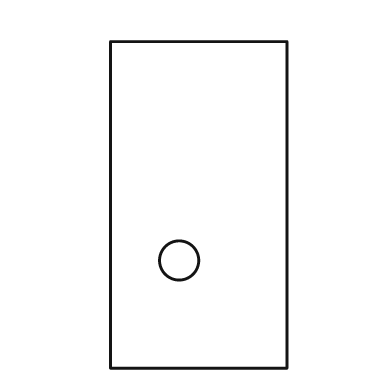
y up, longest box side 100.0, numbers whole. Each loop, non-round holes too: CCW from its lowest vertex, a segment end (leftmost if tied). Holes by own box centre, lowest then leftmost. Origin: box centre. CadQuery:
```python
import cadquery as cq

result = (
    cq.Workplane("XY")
    .moveTo(-27.0, -50.0)
    .lineTo(27.0, -50.0)
    .lineTo(27.0, 50.0)
    .lineTo(-27.0, 50.0)
    .close()
    .moveTo(-6.0, -17.0)
    .circle(6.0)
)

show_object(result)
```